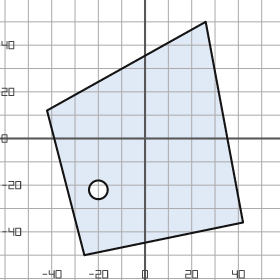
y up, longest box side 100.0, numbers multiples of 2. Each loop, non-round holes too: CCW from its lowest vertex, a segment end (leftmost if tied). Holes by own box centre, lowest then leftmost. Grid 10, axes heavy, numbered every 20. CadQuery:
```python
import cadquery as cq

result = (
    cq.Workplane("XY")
    .moveTo(-26.0, -50.0)
    .lineTo(42.0, -36.0)
    .lineTo(26.0, 50.0)
    .lineTo(-42.0, 12.0)
    .close()
    .moveTo(-20.0, -22.0)
    .circle(4.0)
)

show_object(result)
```